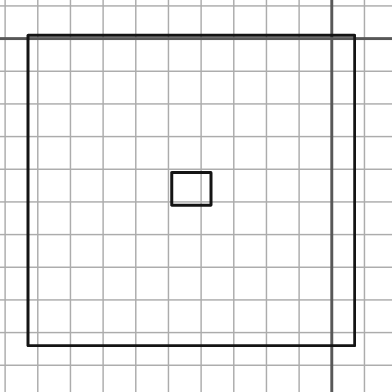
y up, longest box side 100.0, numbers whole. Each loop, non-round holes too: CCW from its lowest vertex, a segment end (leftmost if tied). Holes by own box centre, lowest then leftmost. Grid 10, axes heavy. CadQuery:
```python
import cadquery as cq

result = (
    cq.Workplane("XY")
    .moveTo(-93.0, -94.0)
    .lineTo(7.0, -94.0)
    .lineTo(7.0, 1.0)
    .lineTo(-93.0, 1.0)
    .close()
    .moveTo(-49.0, -51.0)
    .lineTo(-37.0, -51.0)
    .lineTo(-37.0, -41.0)
    .lineTo(-49.0, -41.0)
    .close()
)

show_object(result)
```